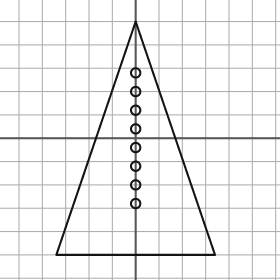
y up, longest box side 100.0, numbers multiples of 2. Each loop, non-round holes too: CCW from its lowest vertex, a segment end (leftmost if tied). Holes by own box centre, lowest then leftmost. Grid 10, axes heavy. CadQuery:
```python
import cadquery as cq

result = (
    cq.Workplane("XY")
    .moveTo(-34.0, -50.0)
    .lineTo(34.0, -50.0)
    .lineTo(0.0, 50.0)
    .close()
    .moveTo(0.0, -28.0)
    .circle(2.0)
    .moveTo(0.0, -20.0)
    .circle(2.0)
    .moveTo(0.0, -12.0)
    .circle(2.0)
    .moveTo(0.0, -4.0)
    .circle(2.0)
    .moveTo(0.0, 4.0)
    .circle(2.0)
    .moveTo(0.0, 12.0)
    .circle(2.0)
    .moveTo(0.0, 20.0)
    .circle(2.0)
    .moveTo(0.0, 28.0)
    .circle(2.0)
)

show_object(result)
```